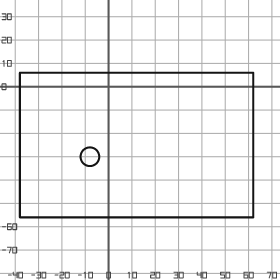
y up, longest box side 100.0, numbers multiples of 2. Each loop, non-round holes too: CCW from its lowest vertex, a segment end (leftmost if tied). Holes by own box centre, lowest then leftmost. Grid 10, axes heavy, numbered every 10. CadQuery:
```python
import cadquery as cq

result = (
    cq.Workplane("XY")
    .moveTo(-38.0, -56.0)
    .lineTo(62.0, -56.0)
    .lineTo(62.0, 6.0)
    .lineTo(-38.0, 6.0)
    .close()
    .moveTo(-8.0, -30.0)
    .circle(4.0)
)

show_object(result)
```